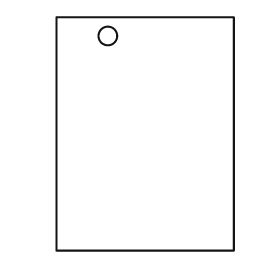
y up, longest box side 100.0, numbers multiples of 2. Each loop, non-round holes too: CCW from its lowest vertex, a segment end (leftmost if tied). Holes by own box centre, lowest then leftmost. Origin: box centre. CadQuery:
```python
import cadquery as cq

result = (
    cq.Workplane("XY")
    .moveTo(-38.0, -50.0)
    .lineTo(38.0, -50.0)
    .lineTo(38.0, 50.0)
    .lineTo(-38.0, 50.0)
    .close()
    .moveTo(-16.0, 42.0)
    .circle(4.0)
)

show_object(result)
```